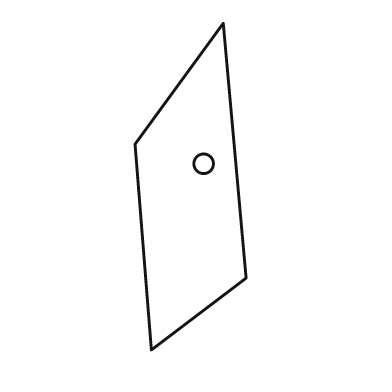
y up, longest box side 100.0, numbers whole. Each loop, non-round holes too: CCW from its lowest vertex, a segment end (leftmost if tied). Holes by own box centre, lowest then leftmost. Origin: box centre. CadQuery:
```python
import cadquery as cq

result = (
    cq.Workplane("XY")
    .moveTo(-12.0, -50.0)
    .lineTo(17.0, -28.0)
    .lineTo(10.0, 50.0)
    .lineTo(-17.0, 13.0)
    .close()
    .moveTo(4.0, 7.0)
    .circle(3.0)
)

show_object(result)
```